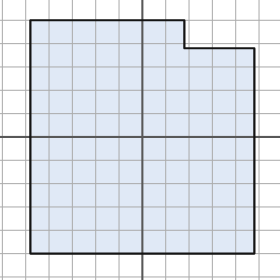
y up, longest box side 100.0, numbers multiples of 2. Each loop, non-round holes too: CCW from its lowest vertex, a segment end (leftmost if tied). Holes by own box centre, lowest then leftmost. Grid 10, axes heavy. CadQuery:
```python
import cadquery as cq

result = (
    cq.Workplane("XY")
    .moveTo(-48.0, -50.0)
    .lineTo(48.0, -50.0)
    .lineTo(48.0, 38.0)
    .lineTo(18.0, 38.0)
    .lineTo(18.0, 50.0)
    .lineTo(-48.0, 50.0)
    .close()
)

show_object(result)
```